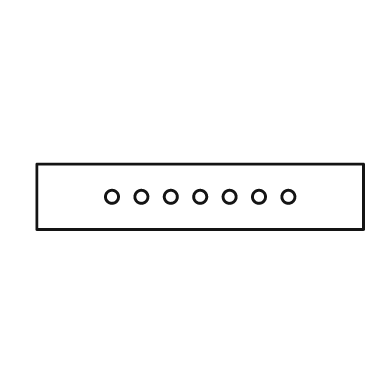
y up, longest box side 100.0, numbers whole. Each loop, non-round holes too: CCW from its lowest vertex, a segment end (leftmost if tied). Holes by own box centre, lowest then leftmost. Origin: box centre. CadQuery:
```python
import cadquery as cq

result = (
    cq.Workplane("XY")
    .moveTo(-50.0, -10.0)
    .lineTo(50.0, -10.0)
    .lineTo(50.0, 10.0)
    .lineTo(-50.0, 10.0)
    .close()
    .moveTo(-27.0, 0.0)
    .circle(2.0)
    .moveTo(-18.0, 0.0)
    .circle(2.0)
    .moveTo(-9.0, 0.0)
    .circle(2.0)
    .moveTo(0.0, 0.0)
    .circle(2.0)
    .moveTo(9.0, 0.0)
    .circle(2.0)
    .moveTo(18.0, 0.0)
    .circle(2.0)
    .moveTo(27.0, 0.0)
    .circle(2.0)
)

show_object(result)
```